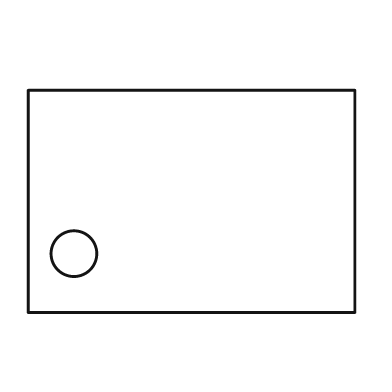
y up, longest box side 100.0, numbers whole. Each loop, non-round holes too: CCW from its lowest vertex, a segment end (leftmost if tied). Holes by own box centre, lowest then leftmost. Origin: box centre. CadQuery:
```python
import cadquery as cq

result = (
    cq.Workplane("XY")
    .moveTo(-50.0, -34.0)
    .lineTo(50.0, -34.0)
    .lineTo(50.0, 34.0)
    .lineTo(-50.0, 34.0)
    .close()
    .moveTo(-36.0, -16.0)
    .circle(7.0)
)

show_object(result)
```